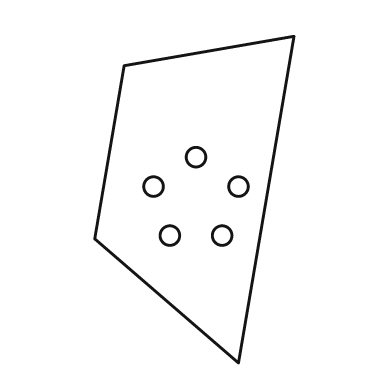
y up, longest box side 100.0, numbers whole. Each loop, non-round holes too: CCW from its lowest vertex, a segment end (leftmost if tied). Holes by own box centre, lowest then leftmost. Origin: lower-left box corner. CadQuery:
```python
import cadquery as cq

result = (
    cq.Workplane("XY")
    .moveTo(44.0, 0.0)
    .lineTo(61.0, 100.0)
    .lineTo(9.0, 91.0)
    .lineTo(0.0, 38.0)
    .close()
    .moveTo(23.0, 39.0)
    .circle(3.0)
    .moveTo(39.0, 39.0)
    .circle(3.0)
    .moveTo(18.0, 54.0)
    .circle(3.0)
    .moveTo(44.0, 54.0)
    .circle(3.0)
    .moveTo(31.0, 63.0)
    .circle(3.0)
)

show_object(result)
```